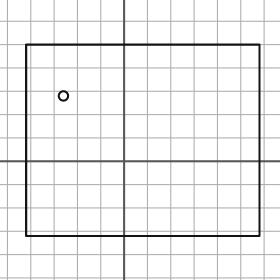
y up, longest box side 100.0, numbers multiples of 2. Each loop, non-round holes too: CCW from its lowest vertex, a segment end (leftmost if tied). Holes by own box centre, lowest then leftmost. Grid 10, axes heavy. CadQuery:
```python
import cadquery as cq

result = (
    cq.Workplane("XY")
    .moveTo(-42.0, -32.0)
    .lineTo(58.0, -32.0)
    .lineTo(58.0, 50.0)
    .lineTo(-42.0, 50.0)
    .close()
    .moveTo(-26.0, 28.0)
    .circle(2.0)
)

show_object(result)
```